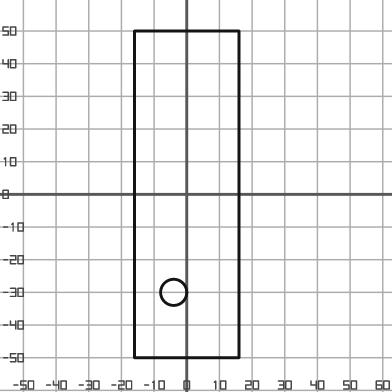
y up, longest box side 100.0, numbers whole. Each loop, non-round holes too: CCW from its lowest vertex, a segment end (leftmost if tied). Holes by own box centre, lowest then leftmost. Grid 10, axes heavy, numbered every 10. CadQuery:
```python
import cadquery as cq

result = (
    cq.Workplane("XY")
    .moveTo(-16.0, -50.0)
    .lineTo(16.0, -50.0)
    .lineTo(16.0, 50.0)
    .lineTo(-16.0, 50.0)
    .close()
    .moveTo(-4.0, -30.0)
    .circle(4.0)
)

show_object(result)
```